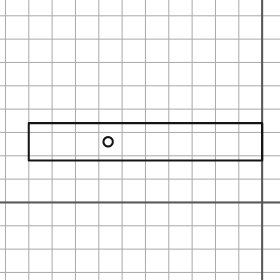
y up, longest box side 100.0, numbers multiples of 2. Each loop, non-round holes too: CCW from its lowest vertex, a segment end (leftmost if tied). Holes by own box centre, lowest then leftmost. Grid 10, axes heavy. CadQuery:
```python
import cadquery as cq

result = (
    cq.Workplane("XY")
    .moveTo(-100.0, 18.0)
    .lineTo(0.0, 18.0)
    .lineTo(0.0, 34.0)
    .lineTo(-100.0, 34.0)
    .close()
    .moveTo(-66.0, 26.0)
    .circle(2.0)
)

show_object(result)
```